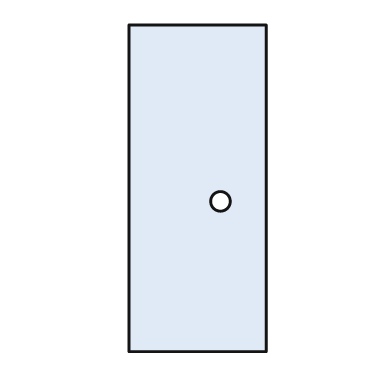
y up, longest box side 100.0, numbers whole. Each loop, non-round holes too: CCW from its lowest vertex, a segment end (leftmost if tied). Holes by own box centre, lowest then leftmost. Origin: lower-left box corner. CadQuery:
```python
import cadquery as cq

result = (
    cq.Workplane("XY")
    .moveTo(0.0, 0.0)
    .lineTo(42.0, 0.0)
    .lineTo(42.0, 100.0)
    .lineTo(0.0, 100.0)
    .close()
    .moveTo(28.0, 46.0)
    .circle(3.0)
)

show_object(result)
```